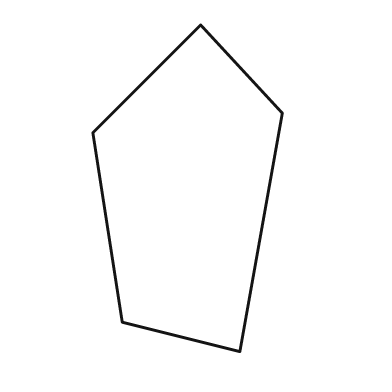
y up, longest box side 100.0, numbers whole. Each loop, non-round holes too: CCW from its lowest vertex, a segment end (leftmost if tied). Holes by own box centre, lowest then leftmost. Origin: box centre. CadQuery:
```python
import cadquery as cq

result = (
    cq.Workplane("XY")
    .moveTo(16.0, -50.0)
    .lineTo(29.0, 23.0)
    .lineTo(4.0, 50.0)
    .lineTo(-29.0, 17.0)
    .lineTo(-20.0, -41.0)
    .close()
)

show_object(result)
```